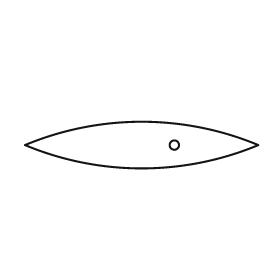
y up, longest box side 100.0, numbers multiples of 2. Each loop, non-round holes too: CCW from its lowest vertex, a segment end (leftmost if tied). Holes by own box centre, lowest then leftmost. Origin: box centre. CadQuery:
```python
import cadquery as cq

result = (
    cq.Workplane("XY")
    .moveTo(-50.0, 0.0)
    .threePointArc((0.0, -10.0), (50.0, 0.0))
    .threePointArc((0.0, 10.0), (-50.0, 0.0))
    .close()
    .moveTo(14.0, 0.0)
    .circle(2.0)
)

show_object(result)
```